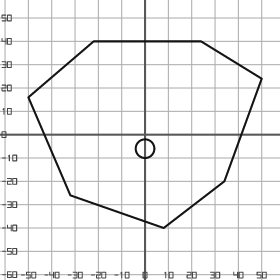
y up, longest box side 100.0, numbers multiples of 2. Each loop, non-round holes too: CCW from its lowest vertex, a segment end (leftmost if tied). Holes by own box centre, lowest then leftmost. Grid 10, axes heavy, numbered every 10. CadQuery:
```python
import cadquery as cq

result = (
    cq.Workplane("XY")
    .moveTo(8.0, -40.0)
    .lineTo(34.0, -20.0)
    .lineTo(50.0, 24.0)
    .lineTo(24.0, 40.0)
    .lineTo(-22.0, 40.0)
    .lineTo(-50.0, 16.0)
    .lineTo(-32.0, -26.0)
    .close()
    .moveTo(0.0, -6.0)
    .circle(4.0)
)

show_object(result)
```